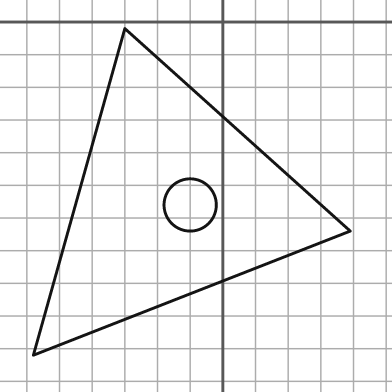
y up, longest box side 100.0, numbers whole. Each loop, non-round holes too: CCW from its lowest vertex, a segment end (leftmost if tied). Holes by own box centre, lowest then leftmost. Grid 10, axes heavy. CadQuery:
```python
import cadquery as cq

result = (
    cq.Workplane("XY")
    .moveTo(-58.0, -102.0)
    .lineTo(39.0, -64.0)
    .lineTo(-30.0, -2.0)
    .close()
    .moveTo(-10.0, -56.0)
    .circle(8.0)
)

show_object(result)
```